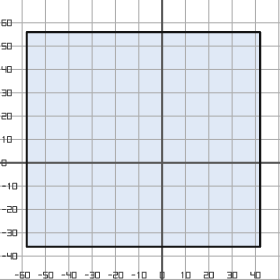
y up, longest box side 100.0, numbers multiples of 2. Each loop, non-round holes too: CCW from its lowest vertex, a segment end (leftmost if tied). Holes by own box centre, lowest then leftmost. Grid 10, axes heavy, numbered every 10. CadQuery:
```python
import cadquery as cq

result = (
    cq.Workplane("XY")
    .moveTo(-58.0, -36.0)
    .lineTo(42.0, -36.0)
    .lineTo(42.0, 56.0)
    .lineTo(-58.0, 56.0)
    .close()
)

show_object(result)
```